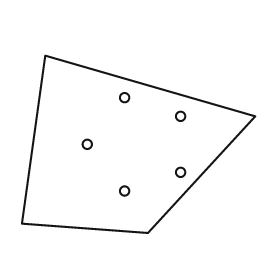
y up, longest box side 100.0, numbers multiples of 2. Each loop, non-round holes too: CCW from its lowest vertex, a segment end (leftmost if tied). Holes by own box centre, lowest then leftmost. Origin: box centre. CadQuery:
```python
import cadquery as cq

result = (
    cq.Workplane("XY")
    .moveTo(4.0, -38.0)
    .lineTo(50.0, 12.0)
    .lineTo(-40.0, 38.0)
    .lineTo(-50.0, -34.0)
    .close()
    .moveTo(-6.0, -20.0)
    .circle(2.0)
    .moveTo(18.0, -12.0)
    .circle(2.0)
    .moveTo(-22.0, 0.0)
    .circle(2.0)
    .moveTo(18.0, 12.0)
    .circle(2.0)
    .moveTo(-6.0, 20.0)
    .circle(2.0)
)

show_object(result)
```